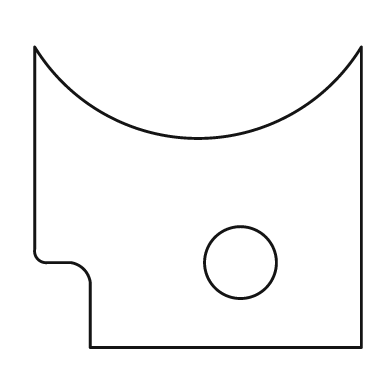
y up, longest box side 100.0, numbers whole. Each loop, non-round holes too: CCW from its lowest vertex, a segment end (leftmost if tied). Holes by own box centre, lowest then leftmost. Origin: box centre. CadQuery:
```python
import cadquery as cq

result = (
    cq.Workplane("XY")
    .moveTo(-33.0, -46.0)
    .lineTo(50.0, -46.0)
    .lineTo(50.0, 46.0)
    .threePointArc((0.0, 18.0), (-50.0, 46.0))
    .lineTo(-50.0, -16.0)
    .threePointArc((-49.0, -19.0), (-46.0, -20.0))
    .lineTo(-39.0, -20.0)
    .threePointArc((-35.0, -22.0), (-33.0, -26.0))
    .close()
    .moveTo(13.0, -20.0)
    .circle(11.0)
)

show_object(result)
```